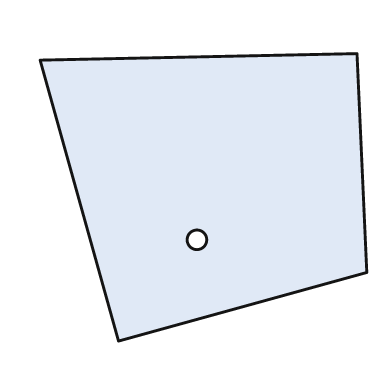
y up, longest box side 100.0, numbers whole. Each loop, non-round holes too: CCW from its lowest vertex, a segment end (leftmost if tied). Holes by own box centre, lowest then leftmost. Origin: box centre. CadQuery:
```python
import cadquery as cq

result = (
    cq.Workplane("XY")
    .moveTo(-26.0, -44.0)
    .lineTo(50.0, -23.0)
    .lineTo(47.0, 44.0)
    .lineTo(-50.0, 42.0)
    .close()
    .moveTo(-2.0, -13.0)
    .circle(3.0)
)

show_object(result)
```